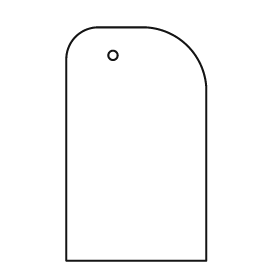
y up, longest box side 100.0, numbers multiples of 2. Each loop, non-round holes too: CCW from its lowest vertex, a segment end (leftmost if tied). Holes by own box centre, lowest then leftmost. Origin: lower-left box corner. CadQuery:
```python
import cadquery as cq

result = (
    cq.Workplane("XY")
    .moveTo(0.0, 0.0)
    .lineTo(60.0, 0.0)
    .lineTo(60.0, 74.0)
    .threePointArc((52.0, 92.0), (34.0, 100.0))
    .lineTo(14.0, 100.0)
    .threePointArc((4.0, 96.0), (0.0, 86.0))
    .close()
    .moveTo(20.0, 88.0)
    .circle(2.0)
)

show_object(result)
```